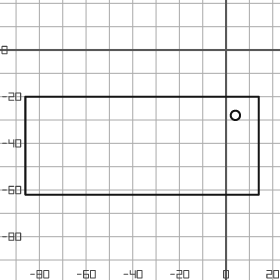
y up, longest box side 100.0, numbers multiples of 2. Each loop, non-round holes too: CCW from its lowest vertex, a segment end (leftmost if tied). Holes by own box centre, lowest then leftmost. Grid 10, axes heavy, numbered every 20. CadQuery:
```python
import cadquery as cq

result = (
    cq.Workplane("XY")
    .moveTo(-86.0, -62.0)
    .lineTo(14.0, -62.0)
    .lineTo(14.0, -20.0)
    .lineTo(-86.0, -20.0)
    .close()
    .moveTo(4.0, -28.0)
    .circle(2.0)
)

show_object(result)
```